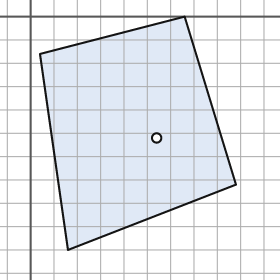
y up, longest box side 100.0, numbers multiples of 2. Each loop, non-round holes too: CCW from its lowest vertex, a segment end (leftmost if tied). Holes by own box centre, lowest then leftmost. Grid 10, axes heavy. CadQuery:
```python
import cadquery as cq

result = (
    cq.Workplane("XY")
    .moveTo(16.0, -100.0)
    .lineTo(88.0, -72.0)
    .lineTo(66.0, 0.0)
    .lineTo(4.0, -16.0)
    .close()
    .moveTo(54.0, -52.0)
    .circle(2.0)
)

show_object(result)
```